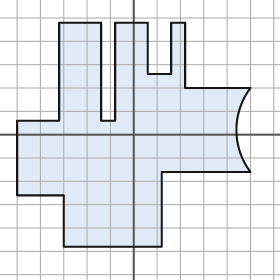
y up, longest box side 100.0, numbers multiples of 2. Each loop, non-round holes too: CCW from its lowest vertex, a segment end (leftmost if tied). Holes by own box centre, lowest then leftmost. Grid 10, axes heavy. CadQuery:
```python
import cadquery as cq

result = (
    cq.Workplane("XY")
    .moveTo(-30.0, -48.0)
    .lineTo(12.0, -48.0)
    .lineTo(12.0, -16.0)
    .lineTo(50.0, -16.0)
    .threePointArc((44.0, 2.0), (50.0, 20.0))
    .lineTo(22.0, 20.0)
    .lineTo(22.0, 48.0)
    .lineTo(16.0, 48.0)
    .lineTo(16.0, 26.0)
    .lineTo(6.0, 26.0)
    .lineTo(6.0, 48.0)
    .lineTo(-8.0, 48.0)
    .lineTo(-8.0, 6.0)
    .lineTo(-14.0, 6.0)
    .lineTo(-14.0, 48.0)
    .lineTo(-32.0, 48.0)
    .lineTo(-32.0, 6.0)
    .lineTo(-50.0, 6.0)
    .lineTo(-50.0, -26.0)
    .lineTo(-30.0, -26.0)
    .close()
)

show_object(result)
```